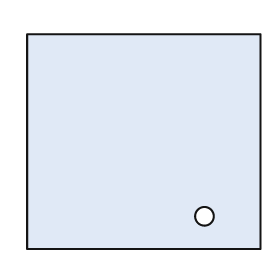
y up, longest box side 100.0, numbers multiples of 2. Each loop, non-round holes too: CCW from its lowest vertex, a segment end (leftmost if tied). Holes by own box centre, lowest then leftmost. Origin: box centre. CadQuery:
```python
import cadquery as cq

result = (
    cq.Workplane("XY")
    .moveTo(-50.0, -46.0)
    .lineTo(50.0, -46.0)
    .lineTo(50.0, 46.0)
    .lineTo(-50.0, 46.0)
    .close()
    .moveTo(26.0, -32.0)
    .circle(4.0)
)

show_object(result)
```